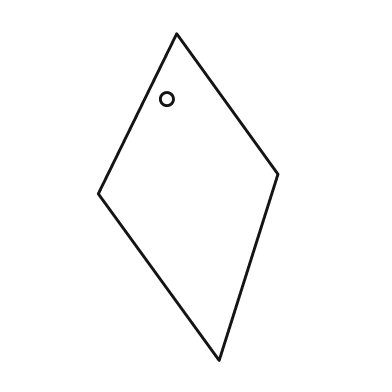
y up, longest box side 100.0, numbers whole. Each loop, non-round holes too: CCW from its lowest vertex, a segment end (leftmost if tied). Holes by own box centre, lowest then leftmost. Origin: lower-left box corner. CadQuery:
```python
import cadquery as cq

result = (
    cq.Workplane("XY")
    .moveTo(37.0, 0.0)
    .lineTo(55.0, 57.0)
    .lineTo(24.0, 100.0)
    .lineTo(0.0, 51.0)
    .close()
    .moveTo(21.0, 80.0)
    .circle(2.0)
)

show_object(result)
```